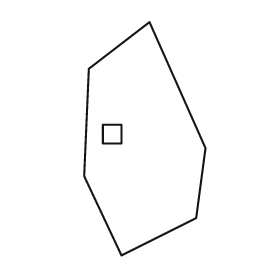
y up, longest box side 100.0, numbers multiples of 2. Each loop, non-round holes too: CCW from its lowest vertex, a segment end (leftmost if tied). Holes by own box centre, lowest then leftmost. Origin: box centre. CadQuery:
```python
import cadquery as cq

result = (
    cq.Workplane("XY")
    .moveTo(-10.0, -50.0)
    .lineTo(22.0, -34.0)
    .lineTo(26.0, -4.0)
    .lineTo(2.0, 50.0)
    .lineTo(-24.0, 30.0)
    .lineTo(-26.0, -16.0)
    .close()
    .moveTo(-18.0, -2.0)
    .lineTo(-10.0, -2.0)
    .lineTo(-10.0, 6.0)
    .lineTo(-18.0, 6.0)
    .close()
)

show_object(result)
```